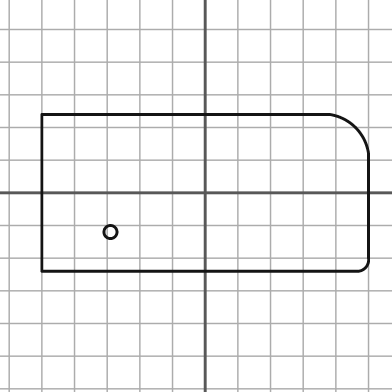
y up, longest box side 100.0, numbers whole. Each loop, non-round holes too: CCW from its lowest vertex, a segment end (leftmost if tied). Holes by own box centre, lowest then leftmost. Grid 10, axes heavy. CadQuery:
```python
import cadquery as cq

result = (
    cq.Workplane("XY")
    .moveTo(-50.0, -24.0)
    .lineTo(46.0, -24.0)
    .threePointArc((49.0, -23.0), (50.0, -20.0))
    .lineTo(50.0, 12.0)
    .threePointArc((46.0, 20.0), (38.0, 24.0))
    .lineTo(-50.0, 24.0)
    .close()
    .moveTo(-29.0, -12.0)
    .circle(2.0)
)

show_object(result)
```